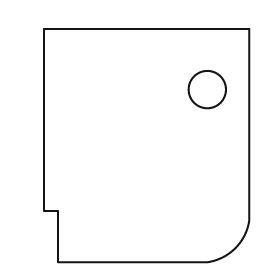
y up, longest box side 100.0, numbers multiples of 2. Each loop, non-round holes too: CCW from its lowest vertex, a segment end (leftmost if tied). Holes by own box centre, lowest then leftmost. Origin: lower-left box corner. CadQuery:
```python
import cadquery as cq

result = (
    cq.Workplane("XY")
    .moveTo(6.0, 0.0)
    .lineTo(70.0, 0.0)
    .threePointArc((82.0, 6.0), (88.0, 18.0))
    .lineTo(88.0, 100.0)
    .lineTo(0.0, 100.0)
    .lineTo(0.0, 22.0)
    .lineTo(6.0, 22.0)
    .close()
    .moveTo(70.0, 74.0)
    .circle(8.0)
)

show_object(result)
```